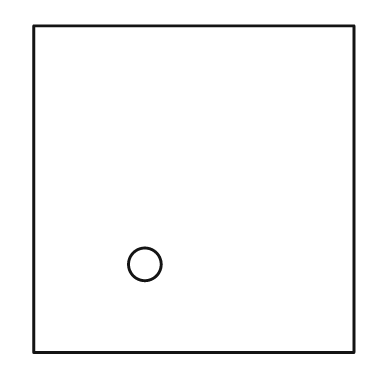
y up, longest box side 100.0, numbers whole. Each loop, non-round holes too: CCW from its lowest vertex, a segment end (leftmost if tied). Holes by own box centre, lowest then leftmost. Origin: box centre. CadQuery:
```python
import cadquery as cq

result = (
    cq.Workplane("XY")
    .moveTo(-49.0, -50.0)
    .lineTo(49.0, -50.0)
    .lineTo(49.0, 50.0)
    .lineTo(-49.0, 50.0)
    .close()
    .moveTo(-15.0, -23.0)
    .circle(5.0)
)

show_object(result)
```